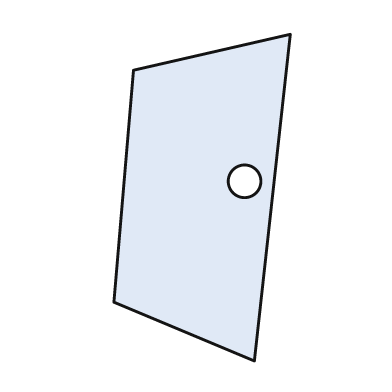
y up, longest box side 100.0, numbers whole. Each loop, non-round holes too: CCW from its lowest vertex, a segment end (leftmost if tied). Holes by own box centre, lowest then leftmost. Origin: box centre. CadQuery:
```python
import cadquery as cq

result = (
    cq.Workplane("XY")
    .moveTo(16.0, -50.0)
    .lineTo(27.0, 50.0)
    .lineTo(-21.0, 39.0)
    .lineTo(-27.0, -32.0)
    .close()
    .moveTo(13.0, 5.0)
    .circle(5.0)
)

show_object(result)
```